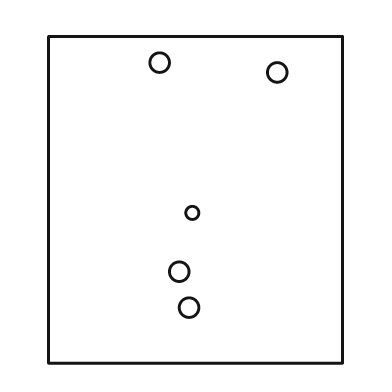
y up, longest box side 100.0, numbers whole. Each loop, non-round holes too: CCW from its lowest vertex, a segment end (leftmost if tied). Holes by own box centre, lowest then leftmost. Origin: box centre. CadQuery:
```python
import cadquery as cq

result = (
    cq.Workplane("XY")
    .moveTo(-45.0, -50.0)
    .lineTo(45.0, -50.0)
    .lineTo(45.0, 50.0)
    .lineTo(-45.0, 50.0)
    .close()
    .moveTo(-2.0, -33.0)
    .circle(3.0)
    .moveTo(-5.0, -22.0)
    .circle(3.0)
    .moveTo(-1.0, -4.0)
    .circle(2.0)
    .moveTo(25.0, 39.0)
    .circle(3.0)
    .moveTo(-11.0, 42.0)
    .circle(3.0)
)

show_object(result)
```